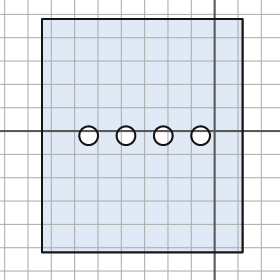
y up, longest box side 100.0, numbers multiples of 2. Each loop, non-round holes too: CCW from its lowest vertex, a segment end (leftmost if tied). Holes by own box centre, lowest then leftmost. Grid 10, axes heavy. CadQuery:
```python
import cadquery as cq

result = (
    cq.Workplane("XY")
    .moveTo(-74.0, -52.0)
    .lineTo(12.0, -52.0)
    .lineTo(12.0, 48.0)
    .lineTo(-74.0, 48.0)
    .close()
    .moveTo(-54.0, -2.0)
    .circle(4.0)
    .moveTo(-38.0, -2.0)
    .circle(4.0)
    .moveTo(-22.0, -2.0)
    .circle(4.0)
    .moveTo(-6.0, -2.0)
    .circle(4.0)
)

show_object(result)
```